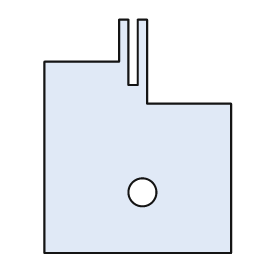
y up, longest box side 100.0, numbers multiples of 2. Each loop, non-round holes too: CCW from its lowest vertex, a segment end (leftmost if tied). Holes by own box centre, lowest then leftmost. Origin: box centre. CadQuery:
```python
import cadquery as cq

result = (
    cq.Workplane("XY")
    .moveTo(-40.0, -50.0)
    .lineTo(40.0, -50.0)
    .lineTo(40.0, 14.0)
    .lineTo(4.0, 14.0)
    .lineTo(4.0, 50.0)
    .lineTo(0.0, 50.0)
    .lineTo(0.0, 22.0)
    .lineTo(-4.0, 22.0)
    .lineTo(-4.0, 50.0)
    .lineTo(-8.0, 50.0)
    .lineTo(-8.0, 32.0)
    .lineTo(-40.0, 32.0)
    .close()
    .moveTo(2.0, -24.0)
    .circle(6.0)
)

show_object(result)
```